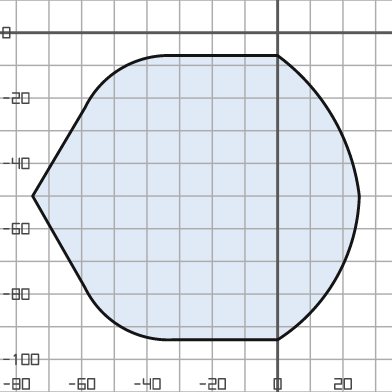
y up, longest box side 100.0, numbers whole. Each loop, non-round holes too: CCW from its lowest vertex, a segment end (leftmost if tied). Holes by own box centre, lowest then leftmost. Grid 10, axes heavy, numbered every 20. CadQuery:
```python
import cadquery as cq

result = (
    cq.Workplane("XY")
    .moveTo(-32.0, -94.0)
    .lineTo(0.0, -94.0)
    .threePointArc((18.0, -75.0), (25.0, -50.0))
    .threePointArc((17.0, -26.0), (0.0, -7.0))
    .lineTo(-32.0, -7.0)
    .threePointArc((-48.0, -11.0), (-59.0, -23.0))
    .lineTo(-75.0, -50.0)
    .lineTo(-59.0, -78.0)
    .threePointArc((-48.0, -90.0), (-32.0, -94.0))
    .close()
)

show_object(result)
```